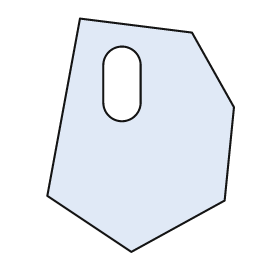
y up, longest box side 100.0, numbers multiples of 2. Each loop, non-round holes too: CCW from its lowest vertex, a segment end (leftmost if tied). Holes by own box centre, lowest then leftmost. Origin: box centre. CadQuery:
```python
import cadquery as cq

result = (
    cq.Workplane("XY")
    .moveTo(-4.0, -50.0)
    .lineTo(36.0, -28.0)
    .lineTo(40.0, 12.0)
    .lineTo(22.0, 44.0)
    .lineTo(-26.0, 50.0)
    .lineTo(-40.0, -26.0)
    .close()
    .moveTo(-16.0, 14.0)
    .threePointArc((-8.0, 6.0), (0.0, 14.0))
    .lineTo(0.0, 30.0)
    .threePointArc((-8.0, 38.0), (-16.0, 30.0))
    .close()
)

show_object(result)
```